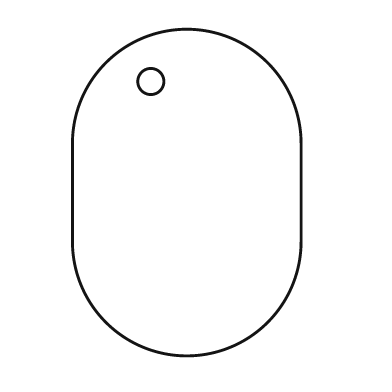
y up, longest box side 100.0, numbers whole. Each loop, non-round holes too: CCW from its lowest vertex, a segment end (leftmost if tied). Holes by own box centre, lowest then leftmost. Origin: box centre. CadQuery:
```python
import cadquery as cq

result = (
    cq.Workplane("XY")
    .moveTo(-35.0, -15.0)
    .threePointArc((0.0, -50.0), (35.0, -15.0))
    .lineTo(35.0, 15.0)
    .threePointArc((0.0, 50.0), (-35.0, 15.0))
    .close()
    .moveTo(-11.0, 34.0)
    .circle(4.0)
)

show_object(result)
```